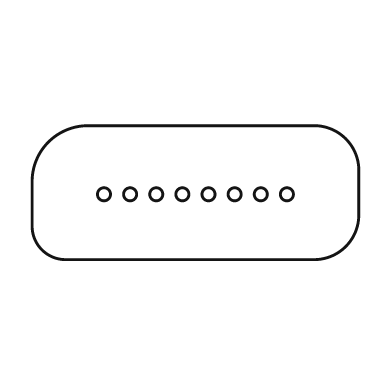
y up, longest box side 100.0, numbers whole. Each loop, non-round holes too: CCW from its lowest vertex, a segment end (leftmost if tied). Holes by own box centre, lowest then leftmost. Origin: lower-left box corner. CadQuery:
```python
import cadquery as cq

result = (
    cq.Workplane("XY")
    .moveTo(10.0, 0.0)
    .lineTo(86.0, 0.0)
    .threePointArc((96.0, 4.0), (100.0, 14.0))
    .lineTo(100.0, 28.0)
    .threePointArc((96.0, 37.0), (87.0, 41.0))
    .lineTo(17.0, 41.0)
    .threePointArc((5.0, 36.0), (0.0, 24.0))
    .lineTo(0.0, 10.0)
    .threePointArc((3.0, 3.0), (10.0, 0.0))
    .close()
    .moveTo(22.0, 20.0)
    .circle(2.0)
    .moveTo(30.0, 20.0)
    .circle(2.0)
    .moveTo(38.0, 20.0)
    .circle(2.0)
    .moveTo(46.0, 20.0)
    .circle(2.0)
    .moveTo(54.0, 20.0)
    .circle(2.0)
    .moveTo(62.0, 20.0)
    .circle(2.0)
    .moveTo(70.0, 20.0)
    .circle(2.0)
    .moveTo(78.0, 20.0)
    .circle(2.0)
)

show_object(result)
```